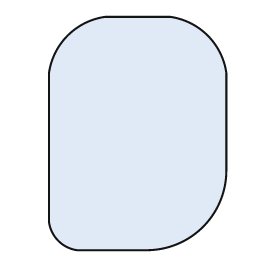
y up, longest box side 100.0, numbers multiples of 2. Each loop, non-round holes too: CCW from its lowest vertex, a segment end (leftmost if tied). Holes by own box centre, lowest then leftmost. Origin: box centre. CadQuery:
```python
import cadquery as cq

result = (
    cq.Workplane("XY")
    .moveTo(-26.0, -50.0)
    .lineTo(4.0, -50.0)
    .threePointArc((28.0, -40.0), (38.0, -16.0))
    .lineTo(38.0, 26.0)
    .threePointArc((30.0, 42.0), (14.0, 50.0))
    .lineTo(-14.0, 50.0)
    .threePointArc((-30.0, 42.0), (-38.0, 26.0))
    .lineTo(-38.0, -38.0)
    .threePointArc((-34.0, -46.0), (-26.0, -50.0))
    .close()
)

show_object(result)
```